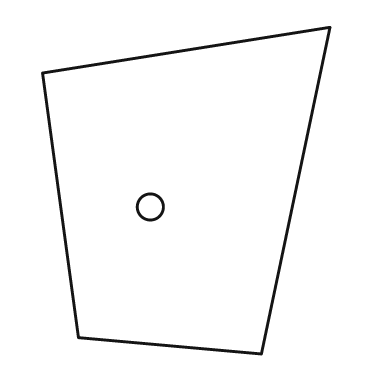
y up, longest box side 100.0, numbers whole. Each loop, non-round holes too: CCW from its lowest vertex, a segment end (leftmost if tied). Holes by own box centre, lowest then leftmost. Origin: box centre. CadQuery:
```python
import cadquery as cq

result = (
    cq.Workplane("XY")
    .moveTo(23.0, -50.0)
    .lineTo(44.0, 50.0)
    .lineTo(-44.0, 36.0)
    .lineTo(-33.0, -45.0)
    .close()
    .moveTo(-11.0, -5.0)
    .circle(4.0)
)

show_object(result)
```